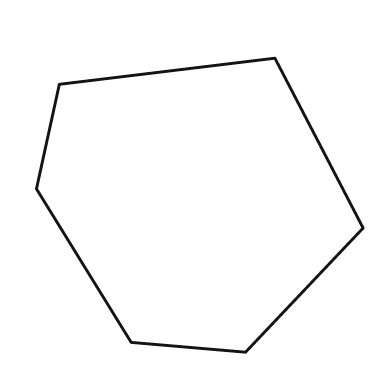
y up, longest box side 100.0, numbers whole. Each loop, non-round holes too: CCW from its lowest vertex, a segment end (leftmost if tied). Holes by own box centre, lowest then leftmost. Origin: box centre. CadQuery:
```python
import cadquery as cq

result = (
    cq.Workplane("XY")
    .moveTo(14.0, -45.0)
    .lineTo(50.0, -7.0)
    .lineTo(23.0, 45.0)
    .lineTo(-43.0, 37.0)
    .lineTo(-50.0, 5.0)
    .lineTo(-21.0, -42.0)
    .close()
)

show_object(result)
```